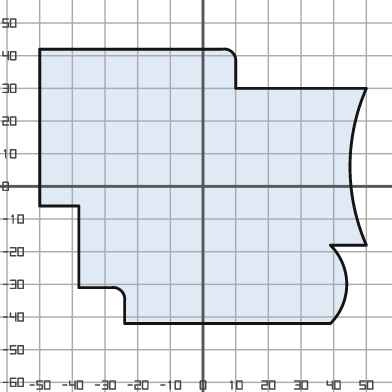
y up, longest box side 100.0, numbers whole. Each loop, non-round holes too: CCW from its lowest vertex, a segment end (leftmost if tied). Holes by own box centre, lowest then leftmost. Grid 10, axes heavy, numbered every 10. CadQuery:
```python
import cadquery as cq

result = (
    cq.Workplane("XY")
    .moveTo(-24.0, -42.0)
    .lineTo(39.0, -42.0)
    .threePointArc((44.0, -30.0), (39.0, -18.0))
    .lineTo(50.0, -18.0)
    .threePointArc((45.0, 6.0), (50.0, 30.0))
    .lineTo(10.0, 30.0)
    .lineTo(10.0, 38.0)
    .threePointArc((9.0, 41.0), (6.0, 42.0))
    .lineTo(-50.0, 42.0)
    .lineTo(-50.0, -6.0)
    .lineTo(-38.0, -6.0)
    .lineTo(-38.0, -31.0)
    .lineTo(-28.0, -31.0)
    .threePointArc((-25.0, -32.0), (-24.0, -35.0))
    .close()
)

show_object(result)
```